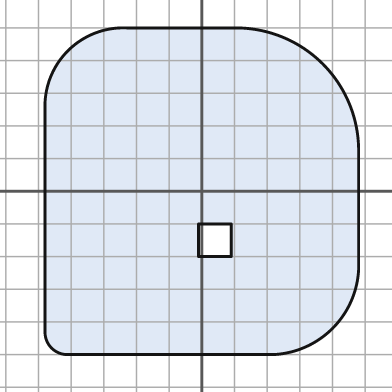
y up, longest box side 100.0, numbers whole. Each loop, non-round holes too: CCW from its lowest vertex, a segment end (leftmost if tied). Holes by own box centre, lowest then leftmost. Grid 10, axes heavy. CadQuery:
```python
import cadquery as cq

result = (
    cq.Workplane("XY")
    .moveTo(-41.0, -50.0)
    .lineTo(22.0, -50.0)
    .threePointArc((40.0, -42.0), (48.0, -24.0))
    .lineTo(48.0, 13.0)
    .threePointArc((37.0, 39.0), (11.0, 50.0))
    .lineTo(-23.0, 50.0)
    .threePointArc((-41.0, 43.0), (-48.0, 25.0))
    .lineTo(-48.0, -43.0)
    .threePointArc((-46.0, -48.0), (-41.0, -50.0))
    .close()
    .moveTo(-1.0, -20.0)
    .lineTo(9.0, -20.0)
    .lineTo(9.0, -10.0)
    .lineTo(-1.0, -10.0)
    .close()
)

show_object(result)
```